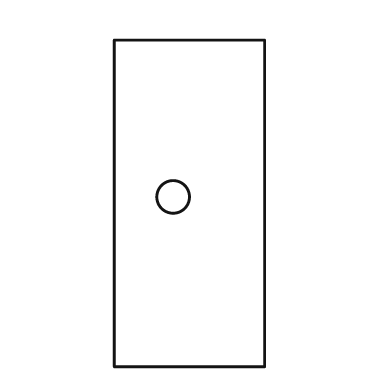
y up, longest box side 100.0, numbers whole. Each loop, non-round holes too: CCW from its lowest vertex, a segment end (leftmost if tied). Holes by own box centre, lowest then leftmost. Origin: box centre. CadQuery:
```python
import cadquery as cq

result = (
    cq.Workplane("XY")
    .moveTo(-23.0, -50.0)
    .lineTo(23.0, -50.0)
    .lineTo(23.0, 50.0)
    .lineTo(-23.0, 50.0)
    .close()
    .moveTo(-5.0, 2.0)
    .circle(5.0)
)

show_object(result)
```